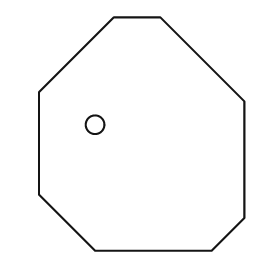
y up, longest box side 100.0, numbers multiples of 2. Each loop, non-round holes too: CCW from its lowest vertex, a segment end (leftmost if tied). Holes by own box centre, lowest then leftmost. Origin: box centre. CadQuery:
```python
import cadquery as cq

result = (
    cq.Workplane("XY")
    .moveTo(-20.0, -50.0)
    .lineTo(30.0, -50.0)
    .lineTo(44.0, -36.0)
    .lineTo(44.0, 14.0)
    .lineTo(8.0, 50.0)
    .lineTo(-12.0, 50.0)
    .lineTo(-44.0, 18.0)
    .lineTo(-44.0, -26.0)
    .close()
    .moveTo(-20.0, 4.0)
    .circle(4.0)
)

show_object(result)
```